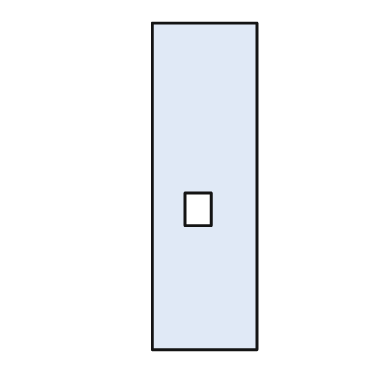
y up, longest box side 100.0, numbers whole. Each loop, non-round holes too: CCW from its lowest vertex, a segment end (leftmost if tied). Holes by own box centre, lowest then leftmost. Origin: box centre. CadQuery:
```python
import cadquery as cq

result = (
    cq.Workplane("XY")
    .moveTo(-16.0, -50.0)
    .lineTo(16.0, -50.0)
    .lineTo(16.0, 50.0)
    .lineTo(-16.0, 50.0)
    .close()
    .moveTo(-6.0, -12.0)
    .lineTo(2.0, -12.0)
    .lineTo(2.0, -2.0)
    .lineTo(-6.0, -2.0)
    .close()
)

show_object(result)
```